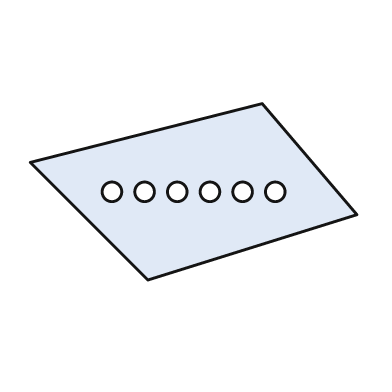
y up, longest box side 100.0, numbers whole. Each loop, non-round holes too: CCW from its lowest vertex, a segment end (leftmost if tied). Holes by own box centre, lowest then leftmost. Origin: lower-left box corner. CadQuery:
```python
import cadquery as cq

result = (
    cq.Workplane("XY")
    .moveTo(36.0, 0.0)
    .lineTo(100.0, 20.0)
    .lineTo(71.0, 54.0)
    .lineTo(0.0, 36.0)
    .close()
    .moveTo(25.0, 27.0)
    .circle(3.0)
    .moveTo(35.0, 27.0)
    .circle(3.0)
    .moveTo(45.0, 27.0)
    .circle(3.0)
    .moveTo(55.0, 27.0)
    .circle(3.0)
    .moveTo(65.0, 27.0)
    .circle(3.0)
    .moveTo(75.0, 27.0)
    .circle(3.0)
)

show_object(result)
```